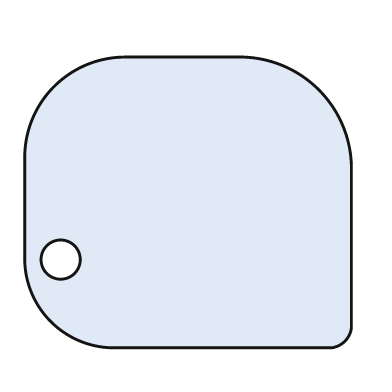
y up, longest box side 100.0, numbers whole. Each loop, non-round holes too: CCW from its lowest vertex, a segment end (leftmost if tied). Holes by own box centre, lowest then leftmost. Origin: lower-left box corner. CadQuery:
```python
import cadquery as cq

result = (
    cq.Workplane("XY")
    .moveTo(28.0, 0.0)
    .lineTo(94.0, 0.0)
    .threePointArc((98.0, 2.0), (100.0, 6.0))
    .lineTo(100.0, 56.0)
    .threePointArc((90.0, 79.0), (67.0, 89.0))
    .lineTo(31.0, 89.0)
    .threePointArc((9.0, 80.0), (0.0, 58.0))
    .lineTo(0.0, 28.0)
    .threePointArc((8.0, 8.0), (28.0, 0.0))
    .close()
    .moveTo(11.0, 27.0)
    .circle(6.0)
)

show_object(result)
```